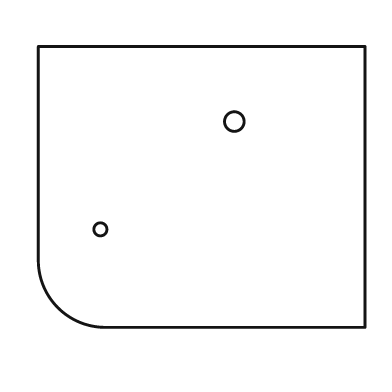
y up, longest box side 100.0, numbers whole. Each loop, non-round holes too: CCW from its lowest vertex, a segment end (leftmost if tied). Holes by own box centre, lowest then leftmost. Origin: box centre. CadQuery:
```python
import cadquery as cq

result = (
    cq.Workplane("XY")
    .moveTo(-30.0, -43.0)
    .lineTo(50.0, -43.0)
    .lineTo(50.0, 43.0)
    .lineTo(-50.0, 43.0)
    .lineTo(-50.0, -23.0)
    .threePointArc((-44.0, -37.0), (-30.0, -43.0))
    .close()
    .moveTo(-31.0, -13.0)
    .circle(2.0)
    .moveTo(10.0, 20.0)
    .circle(3.0)
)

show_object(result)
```